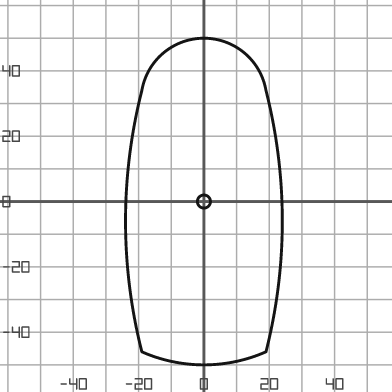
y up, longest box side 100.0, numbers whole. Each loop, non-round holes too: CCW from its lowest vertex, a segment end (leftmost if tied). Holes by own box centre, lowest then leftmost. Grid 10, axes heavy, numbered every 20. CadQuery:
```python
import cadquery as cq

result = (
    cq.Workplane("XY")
    .moveTo(-19.0, -46.0)
    .threePointArc((0.0, -50.0), (19.0, -46.0))
    .threePointArc((24.0, -6.0), (19.0, 34.0))
    .threePointArc((0.0, 50.0), (-19.0, 34.0))
    .threePointArc((-24.0, -6.0), (-19.0, -46.0))
    .close()
    .moveTo(0.0, 0.0)
    .circle(2.0)
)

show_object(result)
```